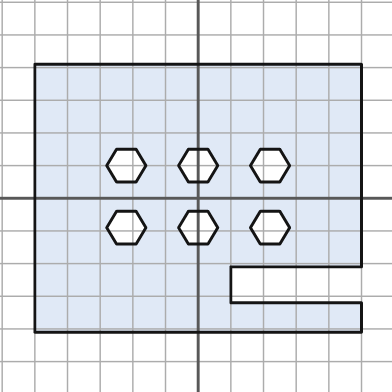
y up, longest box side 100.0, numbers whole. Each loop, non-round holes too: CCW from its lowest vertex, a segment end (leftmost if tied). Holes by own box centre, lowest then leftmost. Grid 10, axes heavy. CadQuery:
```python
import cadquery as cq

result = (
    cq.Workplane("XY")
    .moveTo(-50.0, -41.0)
    .lineTo(50.0, -41.0)
    .lineTo(50.0, -32.0)
    .lineTo(10.0, -32.0)
    .lineTo(10.0, -21.0)
    .lineTo(50.0, -21.0)
    .lineTo(50.0, 41.0)
    .lineTo(-50.0, 41.0)
    .close()
    .moveTo(-25.0, -14.0)
    .lineTo(-19.0, -14.0)
    .lineTo(-16.0, -9.0)
    .lineTo(-19.0, -4.0)
    .lineTo(-25.0, -4.0)
    .lineTo(-28.0, -9.0)
    .close()
    .moveTo(-3.0, -14.0)
    .lineTo(3.0, -14.0)
    .lineTo(6.0, -9.0)
    .lineTo(3.0, -4.0)
    .lineTo(-3.0, -4.0)
    .lineTo(-6.0, -9.0)
    .close()
    .moveTo(19.0, -14.0)
    .lineTo(25.0, -14.0)
    .lineTo(28.0, -9.0)
    .lineTo(25.0, -4.0)
    .lineTo(19.0, -4.0)
    .lineTo(16.0, -9.0)
    .close()
    .moveTo(-25.0, 5.0)
    .lineTo(-19.0, 5.0)
    .lineTo(-16.0, 10.0)
    .lineTo(-19.0, 15.0)
    .lineTo(-25.0, 15.0)
    .lineTo(-28.0, 10.0)
    .close()
    .moveTo(-3.0, 5.0)
    .lineTo(3.0, 5.0)
    .lineTo(6.0, 10.0)
    .lineTo(3.0, 15.0)
    .lineTo(-3.0, 15.0)
    .lineTo(-6.0, 10.0)
    .close()
    .moveTo(19.0, 5.0)
    .lineTo(25.0, 5.0)
    .lineTo(28.0, 10.0)
    .lineTo(25.0, 15.0)
    .lineTo(19.0, 15.0)
    .lineTo(16.0, 10.0)
    .close()
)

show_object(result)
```